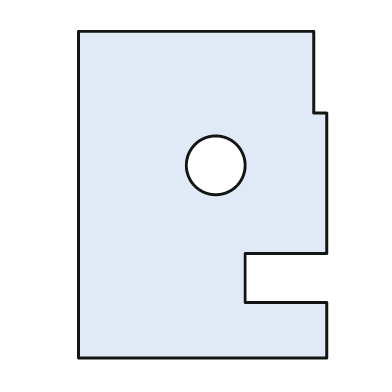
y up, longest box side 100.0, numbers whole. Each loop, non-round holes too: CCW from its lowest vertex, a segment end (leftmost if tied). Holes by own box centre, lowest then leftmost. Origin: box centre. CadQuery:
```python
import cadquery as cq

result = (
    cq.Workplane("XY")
    .moveTo(-38.0, -50.0)
    .lineTo(38.0, -50.0)
    .lineTo(38.0, -33.0)
    .lineTo(13.0, -33.0)
    .lineTo(13.0, -18.0)
    .lineTo(38.0, -18.0)
    .lineTo(38.0, 25.0)
    .lineTo(34.0, 25.0)
    .lineTo(34.0, 50.0)
    .lineTo(-38.0, 50.0)
    .close()
    .moveTo(4.0, 9.0)
    .circle(9.0)
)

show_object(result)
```